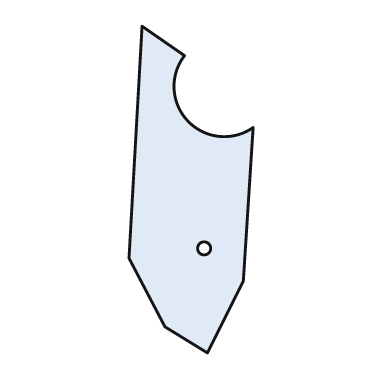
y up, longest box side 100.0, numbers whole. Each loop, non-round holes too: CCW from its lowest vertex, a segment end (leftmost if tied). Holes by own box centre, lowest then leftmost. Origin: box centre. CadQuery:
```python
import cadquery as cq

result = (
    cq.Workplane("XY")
    .moveTo(5.0, -50.0)
    .lineTo(16.0, -28.0)
    .lineTo(19.0, 19.0)
    .threePointArc((-1.0, 21.0), (-2.0, 41.0))
    .lineTo(-15.0, 50.0)
    .lineTo(-19.0, -21.0)
    .lineTo(-8.0, -42.0)
    .close()
    .moveTo(4.0, -18.0)
    .circle(2.0)
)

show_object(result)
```